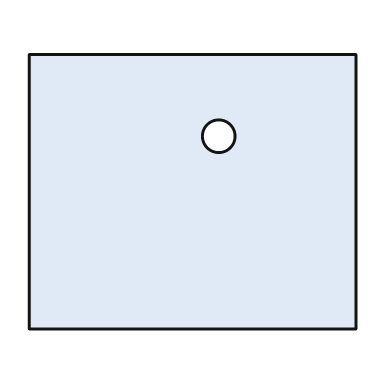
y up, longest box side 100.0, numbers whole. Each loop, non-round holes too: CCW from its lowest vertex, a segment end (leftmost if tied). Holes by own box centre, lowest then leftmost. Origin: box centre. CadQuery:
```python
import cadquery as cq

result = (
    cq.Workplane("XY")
    .moveTo(-50.0, -42.0)
    .lineTo(50.0, -42.0)
    .lineTo(50.0, 42.0)
    .lineTo(-50.0, 42.0)
    .close()
    .moveTo(8.0, 17.0)
    .circle(5.0)
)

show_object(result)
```